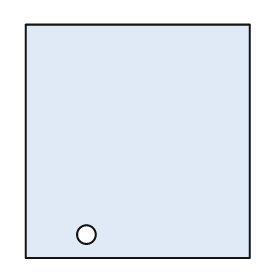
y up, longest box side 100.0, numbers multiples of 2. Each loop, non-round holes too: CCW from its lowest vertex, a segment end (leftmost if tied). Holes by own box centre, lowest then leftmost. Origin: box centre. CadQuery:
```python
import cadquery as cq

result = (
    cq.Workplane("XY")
    .moveTo(-48.0, -50.0)
    .lineTo(48.0, -50.0)
    .lineTo(48.0, 50.0)
    .lineTo(-48.0, 50.0)
    .close()
    .moveTo(-22.0, -40.0)
    .circle(4.0)
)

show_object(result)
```